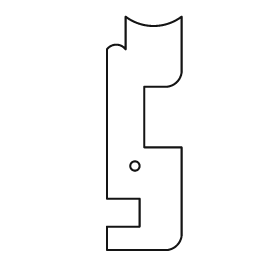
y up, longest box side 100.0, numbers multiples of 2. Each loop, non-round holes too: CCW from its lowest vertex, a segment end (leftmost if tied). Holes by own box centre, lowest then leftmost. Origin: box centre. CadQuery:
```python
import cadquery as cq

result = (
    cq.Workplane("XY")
    .moveTo(-16.0, -50.0)
    .lineTo(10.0, -50.0)
    .threePointArc((14.0, -48.0), (16.0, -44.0))
    .lineTo(16.0, -6.0)
    .lineTo(0.0, -6.0)
    .lineTo(0.0, 20.0)
    .lineTo(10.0, 20.0)
    .threePointArc((14.0, 22.0), (16.0, 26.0))
    .lineTo(16.0, 50.0)
    .threePointArc((4.0, 46.0), (-8.0, 50.0))
    .lineTo(-8.0, 36.0)
    .threePointArc((-12.0, 38.0), (-16.0, 36.0))
    .lineTo(-16.0, -28.0)
    .lineTo(-2.0, -28.0)
    .lineTo(-2.0, -40.0)
    .lineTo(-16.0, -40.0)
    .close()
    .moveTo(-4.0, -14.0)
    .circle(2.0)
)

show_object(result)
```